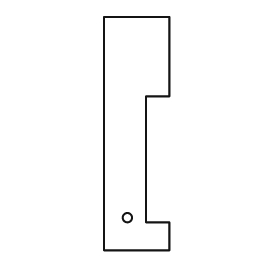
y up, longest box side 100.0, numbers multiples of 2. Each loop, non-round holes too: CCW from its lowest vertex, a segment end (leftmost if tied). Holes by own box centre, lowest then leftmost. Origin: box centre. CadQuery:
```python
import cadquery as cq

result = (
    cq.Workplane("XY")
    .moveTo(-14.0, -50.0)
    .lineTo(14.0, -50.0)
    .lineTo(14.0, -38.0)
    .lineTo(4.0, -38.0)
    .lineTo(4.0, 16.0)
    .lineTo(14.0, 16.0)
    .lineTo(14.0, 50.0)
    .lineTo(-14.0, 50.0)
    .close()
    .moveTo(-4.0, -36.0)
    .circle(2.0)
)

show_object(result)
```